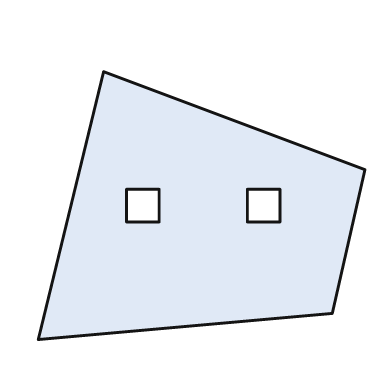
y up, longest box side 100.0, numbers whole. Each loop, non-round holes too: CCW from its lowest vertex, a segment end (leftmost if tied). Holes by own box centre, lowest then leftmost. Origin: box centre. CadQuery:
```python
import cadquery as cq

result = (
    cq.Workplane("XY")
    .moveTo(-50.0, -41.0)
    .lineTo(40.0, -33.0)
    .lineTo(50.0, 11.0)
    .lineTo(-30.0, 41.0)
    .close()
    .moveTo(-23.0, -5.0)
    .lineTo(-13.0, -5.0)
    .lineTo(-13.0, 5.0)
    .lineTo(-23.0, 5.0)
    .close()
    .moveTo(14.0, -5.0)
    .lineTo(24.0, -5.0)
    .lineTo(24.0, 5.0)
    .lineTo(14.0, 5.0)
    .close()
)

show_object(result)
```